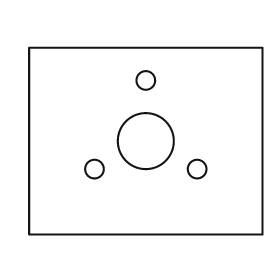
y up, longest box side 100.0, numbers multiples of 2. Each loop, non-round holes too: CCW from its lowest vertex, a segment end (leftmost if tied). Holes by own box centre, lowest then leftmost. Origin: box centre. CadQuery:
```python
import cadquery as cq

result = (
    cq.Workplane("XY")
    .moveTo(-50.0, -40.0)
    .lineTo(50.0, -40.0)
    .lineTo(50.0, 40.0)
    .lineTo(-50.0, 40.0)
    .close()
    .moveTo(-22.0, -12.0)
    .circle(4.0)
    .moveTo(22.0, -12.0)
    .circle(4.0)
    .moveTo(0.0, 0.0)
    .circle(12.0)
    .moveTo(0.0, 26.0)
    .circle(4.0)
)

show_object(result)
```